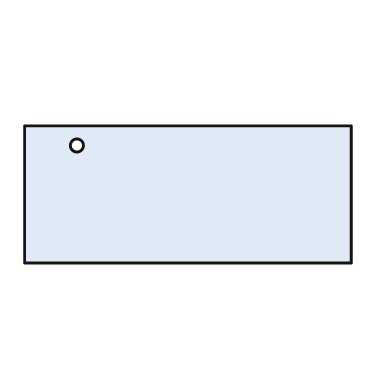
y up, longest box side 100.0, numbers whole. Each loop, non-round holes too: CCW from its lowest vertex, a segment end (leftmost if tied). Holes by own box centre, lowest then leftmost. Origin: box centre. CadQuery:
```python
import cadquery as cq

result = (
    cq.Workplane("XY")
    .moveTo(-50.0, -21.0)
    .lineTo(50.0, -21.0)
    .lineTo(50.0, 21.0)
    .lineTo(-50.0, 21.0)
    .close()
    .moveTo(-34.0, 15.0)
    .circle(2.0)
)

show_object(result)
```